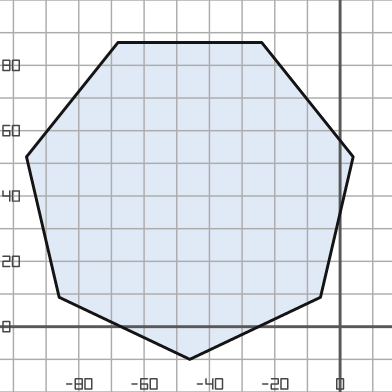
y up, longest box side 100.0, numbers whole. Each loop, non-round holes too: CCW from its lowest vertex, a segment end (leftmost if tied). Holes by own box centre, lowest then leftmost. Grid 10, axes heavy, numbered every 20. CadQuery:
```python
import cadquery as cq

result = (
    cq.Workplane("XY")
    .moveTo(-46.0, -10.0)
    .lineTo(-6.0, 9.0)
    .lineTo(4.0, 52.0)
    .lineTo(-24.0, 87.0)
    .lineTo(-68.0, 87.0)
    .lineTo(-96.0, 52.0)
    .lineTo(-86.0, 9.0)
    .close()
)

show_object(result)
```